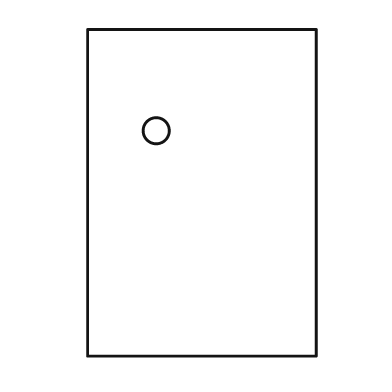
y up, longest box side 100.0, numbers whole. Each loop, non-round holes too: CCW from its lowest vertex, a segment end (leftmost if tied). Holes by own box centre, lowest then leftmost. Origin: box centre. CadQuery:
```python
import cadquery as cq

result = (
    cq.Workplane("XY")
    .moveTo(-35.0, -50.0)
    .lineTo(35.0, -50.0)
    .lineTo(35.0, 50.0)
    .lineTo(-35.0, 50.0)
    .close()
    .moveTo(-14.0, 19.0)
    .circle(4.0)
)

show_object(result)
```